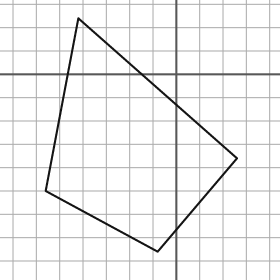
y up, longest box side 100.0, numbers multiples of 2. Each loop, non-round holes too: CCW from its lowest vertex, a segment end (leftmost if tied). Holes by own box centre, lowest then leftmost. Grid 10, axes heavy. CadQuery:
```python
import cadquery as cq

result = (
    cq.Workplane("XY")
    .moveTo(-8.0, -76.0)
    .lineTo(26.0, -36.0)
    .lineTo(-42.0, 24.0)
    .lineTo(-56.0, -50.0)
    .close()
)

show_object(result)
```